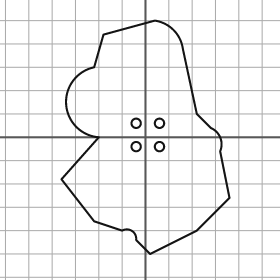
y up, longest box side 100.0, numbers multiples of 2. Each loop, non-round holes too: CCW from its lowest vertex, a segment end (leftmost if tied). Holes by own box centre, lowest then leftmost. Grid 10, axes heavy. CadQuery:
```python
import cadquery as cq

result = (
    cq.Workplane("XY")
    .moveTo(2.0, -50.0)
    .lineTo(22.0, -40.0)
    .lineTo(36.0, -26.0)
    .lineTo(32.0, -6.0)
    .threePointArc((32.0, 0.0), (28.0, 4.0))
    .lineTo(22.0, 10.0)
    .lineTo(16.0, 38.0)
    .threePointArc((12.0, 46.0), (4.0, 50.0))
    .lineTo(-18.0, 44.0)
    .lineTo(-22.0, 30.0)
    .threePointArc((-34.0, 14.0), (-20.0, 0.0))
    .lineTo(-36.0, -18.0)
    .lineTo(-22.0, -36.0)
    .lineTo(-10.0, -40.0)
    .threePointArc((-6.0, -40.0), (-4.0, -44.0))
    .close()
    .moveTo(-4.0, -4.0)
    .circle(2.0)
    .moveTo(6.0, -4.0)
    .circle(2.0)
    .moveTo(-4.0, 6.0)
    .circle(2.0)
    .moveTo(6.0, 6.0)
    .circle(2.0)
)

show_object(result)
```